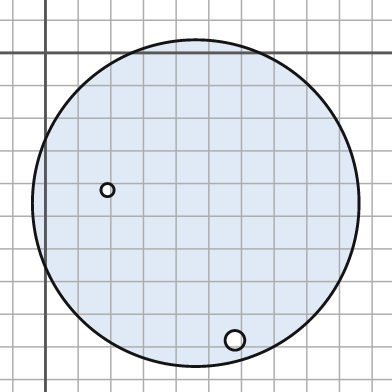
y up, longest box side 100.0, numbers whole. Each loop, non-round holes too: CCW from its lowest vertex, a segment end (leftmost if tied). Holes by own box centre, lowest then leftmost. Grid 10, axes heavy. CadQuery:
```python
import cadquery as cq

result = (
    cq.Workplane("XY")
    .moveTo(46.0, -46.0)
    .circle(50.0)
    .moveTo(58.0, -88.0)
    .circle(3.0)
    .moveTo(19.0, -42.0)
    .circle(2.0)
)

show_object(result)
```